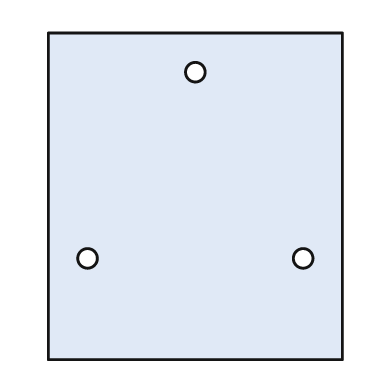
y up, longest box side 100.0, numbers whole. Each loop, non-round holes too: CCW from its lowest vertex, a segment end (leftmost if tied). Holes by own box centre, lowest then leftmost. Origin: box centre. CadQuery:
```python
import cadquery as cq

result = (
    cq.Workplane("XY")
    .moveTo(-45.0, -50.0)
    .lineTo(45.0, -50.0)
    .lineTo(45.0, 50.0)
    .lineTo(-45.0, 50.0)
    .close()
    .moveTo(-33.0, -19.0)
    .circle(3.0)
    .moveTo(33.0, -19.0)
    .circle(3.0)
    .moveTo(0.0, 38.0)
    .circle(3.0)
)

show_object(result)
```